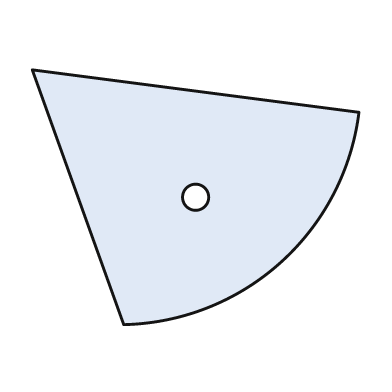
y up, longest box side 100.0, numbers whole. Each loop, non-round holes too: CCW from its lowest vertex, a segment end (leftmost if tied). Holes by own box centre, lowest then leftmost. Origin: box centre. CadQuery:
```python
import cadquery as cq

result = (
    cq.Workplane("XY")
    .moveTo(-22.0, -39.0)
    .threePointArc((26.0, -20.0), (50.0, 26.0))
    .lineTo(-50.0, 39.0)
    .close()
    .moveTo(0.0, 0.0)
    .circle(4.0)
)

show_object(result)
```